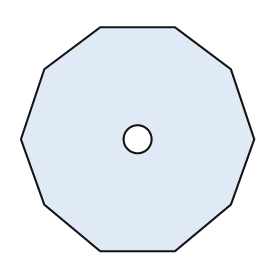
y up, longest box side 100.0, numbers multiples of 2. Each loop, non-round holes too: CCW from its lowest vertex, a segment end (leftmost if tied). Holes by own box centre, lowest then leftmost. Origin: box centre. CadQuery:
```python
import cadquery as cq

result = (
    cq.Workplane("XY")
    .moveTo(-16.0, -48.0)
    .lineTo(16.0, -48.0)
    .lineTo(40.0, -28.0)
    .lineTo(50.0, 0.0)
    .lineTo(40.0, 30.0)
    .lineTo(16.0, 48.0)
    .lineTo(-16.0, 48.0)
    .lineTo(-40.0, 30.0)
    .lineTo(-50.0, 0.0)
    .lineTo(-40.0, -28.0)
    .close()
    .moveTo(0.0, 0.0)
    .circle(6.0)
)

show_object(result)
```